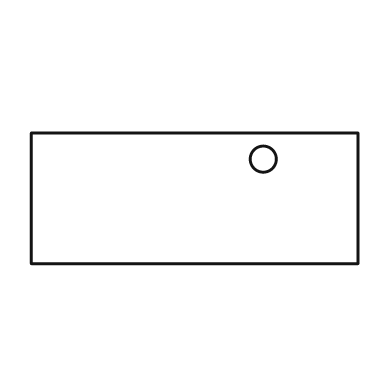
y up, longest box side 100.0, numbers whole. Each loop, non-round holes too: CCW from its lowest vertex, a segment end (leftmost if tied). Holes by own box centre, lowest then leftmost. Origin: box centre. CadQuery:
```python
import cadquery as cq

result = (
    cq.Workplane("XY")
    .moveTo(-50.0, -20.0)
    .lineTo(50.0, -20.0)
    .lineTo(50.0, 20.0)
    .lineTo(-50.0, 20.0)
    .close()
    .moveTo(21.0, 12.0)
    .circle(4.0)
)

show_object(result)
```